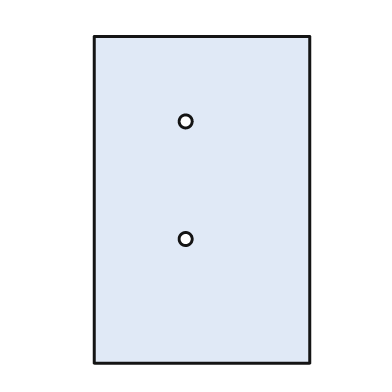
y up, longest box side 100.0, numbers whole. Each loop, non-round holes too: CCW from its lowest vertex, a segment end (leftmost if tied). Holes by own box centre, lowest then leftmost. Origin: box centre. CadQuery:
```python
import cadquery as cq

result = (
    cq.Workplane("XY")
    .moveTo(-33.0, -50.0)
    .lineTo(33.0, -50.0)
    .lineTo(33.0, 50.0)
    .lineTo(-33.0, 50.0)
    .close()
    .moveTo(-5.0, -12.0)
    .circle(2.0)
    .moveTo(-5.0, 24.0)
    .circle(2.0)
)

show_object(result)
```